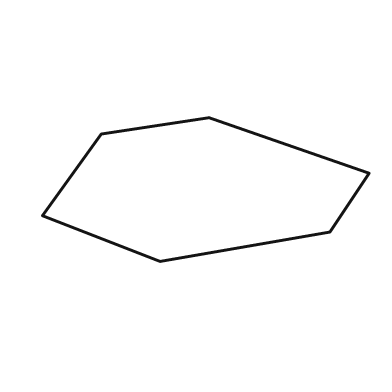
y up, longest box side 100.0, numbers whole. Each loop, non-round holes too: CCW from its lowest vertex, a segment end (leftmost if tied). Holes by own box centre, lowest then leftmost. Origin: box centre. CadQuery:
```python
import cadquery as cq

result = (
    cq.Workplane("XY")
    .moveTo(-14.0, -22.0)
    .lineTo(38.0, -13.0)
    .lineTo(50.0, 5.0)
    .lineTo(1.0, 22.0)
    .lineTo(-32.0, 17.0)
    .lineTo(-50.0, -8.0)
    .close()
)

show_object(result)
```